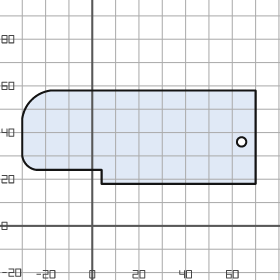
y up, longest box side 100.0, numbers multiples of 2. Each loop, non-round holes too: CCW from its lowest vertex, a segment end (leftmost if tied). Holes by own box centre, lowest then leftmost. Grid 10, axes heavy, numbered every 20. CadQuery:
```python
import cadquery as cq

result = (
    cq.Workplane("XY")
    .moveTo(4.0, 18.0)
    .lineTo(70.0, 18.0)
    .lineTo(70.0, 58.0)
    .lineTo(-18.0, 58.0)
    .threePointArc((-26.0, 54.0), (-30.0, 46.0))
    .lineTo(-30.0, 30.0)
    .threePointArc((-28.0, 26.0), (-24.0, 24.0))
    .lineTo(4.0, 24.0)
    .close()
    .moveTo(64.0, 36.0)
    .circle(2.0)
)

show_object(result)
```